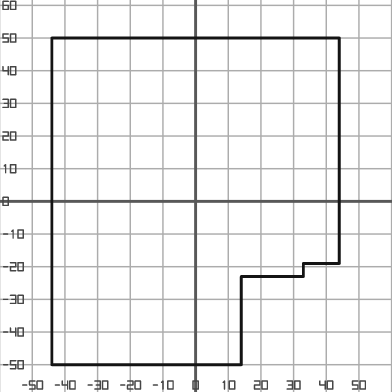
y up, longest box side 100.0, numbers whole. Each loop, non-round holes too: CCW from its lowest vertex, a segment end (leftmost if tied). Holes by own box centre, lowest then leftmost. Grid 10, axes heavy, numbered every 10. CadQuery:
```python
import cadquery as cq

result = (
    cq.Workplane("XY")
    .moveTo(-44.0, -50.0)
    .lineTo(14.0, -50.0)
    .lineTo(14.0, -23.0)
    .lineTo(33.0, -23.0)
    .lineTo(33.0, -19.0)
    .lineTo(44.0, -19.0)
    .lineTo(44.0, 50.0)
    .lineTo(-44.0, 50.0)
    .close()
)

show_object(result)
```